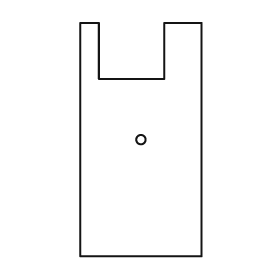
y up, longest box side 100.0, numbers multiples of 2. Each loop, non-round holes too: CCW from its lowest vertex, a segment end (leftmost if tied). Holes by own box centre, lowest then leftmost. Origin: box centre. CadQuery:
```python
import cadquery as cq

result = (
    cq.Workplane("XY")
    .moveTo(-26.0, -50.0)
    .lineTo(26.0, -50.0)
    .lineTo(26.0, 50.0)
    .lineTo(10.0, 50.0)
    .lineTo(10.0, 26.0)
    .lineTo(-18.0, 26.0)
    .lineTo(-18.0, 50.0)
    .lineTo(-26.0, 50.0)
    .close()
    .moveTo(0.0, 0.0)
    .circle(2.0)
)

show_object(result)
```